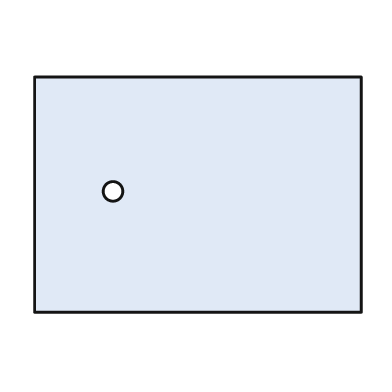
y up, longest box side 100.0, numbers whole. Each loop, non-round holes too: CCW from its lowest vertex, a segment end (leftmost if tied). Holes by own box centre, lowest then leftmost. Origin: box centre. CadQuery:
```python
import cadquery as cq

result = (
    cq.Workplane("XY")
    .moveTo(-50.0, -36.0)
    .lineTo(50.0, -36.0)
    .lineTo(50.0, 36.0)
    .lineTo(-50.0, 36.0)
    .close()
    .moveTo(-26.0, 1.0)
    .circle(3.0)
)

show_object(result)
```